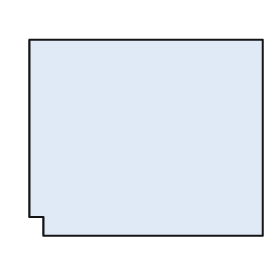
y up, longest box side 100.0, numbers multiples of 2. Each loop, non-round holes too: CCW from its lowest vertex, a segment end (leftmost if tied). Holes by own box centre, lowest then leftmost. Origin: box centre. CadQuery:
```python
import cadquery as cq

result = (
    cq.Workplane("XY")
    .moveTo(-44.0, -42.0)
    .lineTo(50.0, -42.0)
    .lineTo(50.0, 42.0)
    .lineTo(-50.0, 42.0)
    .lineTo(-50.0, -34.0)
    .lineTo(-44.0, -34.0)
    .close()
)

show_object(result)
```